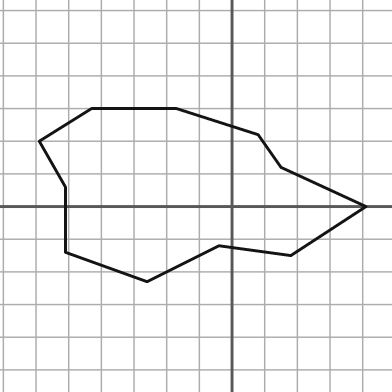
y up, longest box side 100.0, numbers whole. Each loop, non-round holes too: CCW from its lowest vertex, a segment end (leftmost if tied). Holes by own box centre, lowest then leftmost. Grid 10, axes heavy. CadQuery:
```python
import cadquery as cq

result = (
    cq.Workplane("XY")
    .moveTo(-26.0, -23.0)
    .lineTo(-4.0, -12.0)
    .lineTo(18.0, -15.0)
    .lineTo(41.0, 0.0)
    .lineTo(15.0, 12.0)
    .lineTo(8.0, 22.0)
    .lineTo(-17.0, 30.0)
    .lineTo(-43.0, 30.0)
    .lineTo(-59.0, 20.0)
    .lineTo(-51.0, 6.0)
    .lineTo(-51.0, -14.0)
    .close()
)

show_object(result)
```